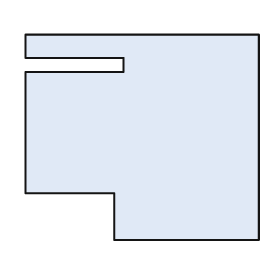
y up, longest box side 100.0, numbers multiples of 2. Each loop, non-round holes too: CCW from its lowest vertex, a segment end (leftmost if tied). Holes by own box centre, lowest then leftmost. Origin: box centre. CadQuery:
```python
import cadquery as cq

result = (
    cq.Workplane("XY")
    .moveTo(-12.0, -44.0)
    .lineTo(50.0, -44.0)
    .lineTo(50.0, 44.0)
    .lineTo(-50.0, 44.0)
    .lineTo(-50.0, 34.0)
    .lineTo(-8.0, 34.0)
    .lineTo(-8.0, 28.0)
    .lineTo(-50.0, 28.0)
    .lineTo(-50.0, -24.0)
    .lineTo(-12.0, -24.0)
    .close()
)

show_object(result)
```